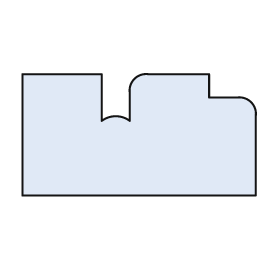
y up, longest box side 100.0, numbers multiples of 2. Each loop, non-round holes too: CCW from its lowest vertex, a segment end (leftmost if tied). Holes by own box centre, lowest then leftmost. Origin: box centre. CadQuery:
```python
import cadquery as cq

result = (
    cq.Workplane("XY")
    .moveTo(-50.0, -26.0)
    .lineTo(50.0, -26.0)
    .lineTo(50.0, 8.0)
    .threePointArc((48.0, 14.0), (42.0, 16.0))
    .lineTo(30.0, 16.0)
    .lineTo(30.0, 26.0)
    .lineTo(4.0, 26.0)
    .threePointArc((-2.0, 24.0), (-4.0, 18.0))
    .lineTo(-4.0, 6.0)
    .threePointArc((-10.0, 8.0), (-16.0, 6.0))
    .lineTo(-16.0, 26.0)
    .lineTo(-50.0, 26.0)
    .close()
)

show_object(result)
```